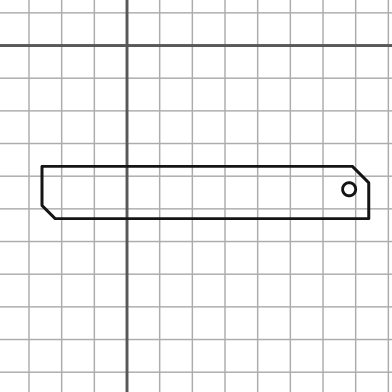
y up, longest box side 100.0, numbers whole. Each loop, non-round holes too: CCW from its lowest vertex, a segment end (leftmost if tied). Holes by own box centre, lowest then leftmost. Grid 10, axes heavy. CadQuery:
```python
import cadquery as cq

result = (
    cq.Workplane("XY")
    .moveTo(-22.0, -53.0)
    .lineTo(74.0, -53.0)
    .lineTo(74.0, -42.0)
    .lineTo(69.0, -37.0)
    .lineTo(-26.0, -37.0)
    .lineTo(-26.0, -49.0)
    .close()
    .moveTo(68.0, -44.0)
    .circle(2.0)
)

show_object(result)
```